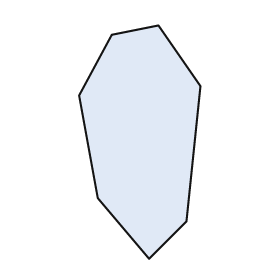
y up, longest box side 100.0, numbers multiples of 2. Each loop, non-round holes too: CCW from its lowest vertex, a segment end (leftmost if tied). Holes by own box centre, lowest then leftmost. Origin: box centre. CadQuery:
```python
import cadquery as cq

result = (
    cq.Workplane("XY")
    .moveTo(4.0, -50.0)
    .lineTo(20.0, -34.0)
    .lineTo(26.0, 24.0)
    .lineTo(8.0, 50.0)
    .lineTo(-12.0, 46.0)
    .lineTo(-26.0, 20.0)
    .lineTo(-18.0, -24.0)
    .close()
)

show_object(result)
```